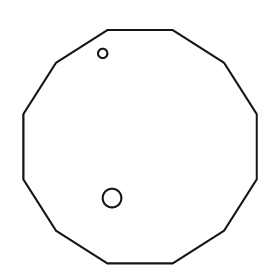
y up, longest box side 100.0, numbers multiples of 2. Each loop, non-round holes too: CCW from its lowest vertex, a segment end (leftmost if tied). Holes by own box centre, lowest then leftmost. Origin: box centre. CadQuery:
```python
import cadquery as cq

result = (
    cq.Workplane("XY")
    .moveTo(-14.0, -50.0)
    .lineTo(14.0, -50.0)
    .lineTo(36.0, -36.0)
    .lineTo(50.0, -14.0)
    .lineTo(50.0, 14.0)
    .lineTo(36.0, 36.0)
    .lineTo(14.0, 50.0)
    .lineTo(-14.0, 50.0)
    .lineTo(-36.0, 36.0)
    .lineTo(-50.0, 14.0)
    .lineTo(-50.0, -14.0)
    .lineTo(-36.0, -36.0)
    .close()
    .moveTo(-12.0, -22.0)
    .circle(4.0)
    .moveTo(-16.0, 40.0)
    .circle(2.0)
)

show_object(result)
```